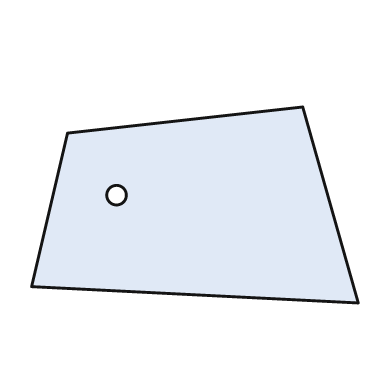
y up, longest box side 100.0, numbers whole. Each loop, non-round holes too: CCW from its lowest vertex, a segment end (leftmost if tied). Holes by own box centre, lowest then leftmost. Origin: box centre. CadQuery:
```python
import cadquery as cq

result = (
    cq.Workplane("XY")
    .moveTo(50.0, -30.0)
    .lineTo(33.0, 30.0)
    .lineTo(-39.0, 22.0)
    .lineTo(-50.0, -25.0)
    .close()
    .moveTo(-24.0, 3.0)
    .circle(3.0)
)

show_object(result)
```